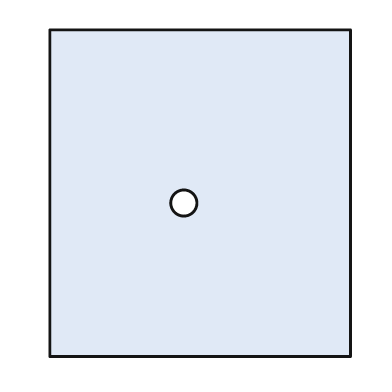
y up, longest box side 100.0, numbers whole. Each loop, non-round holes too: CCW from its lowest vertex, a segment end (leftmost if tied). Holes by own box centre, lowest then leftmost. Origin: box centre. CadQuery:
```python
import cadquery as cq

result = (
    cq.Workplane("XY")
    .moveTo(-46.0, -50.0)
    .lineTo(46.0, -50.0)
    .lineTo(46.0, 50.0)
    .lineTo(-46.0, 50.0)
    .close()
    .moveTo(-5.0, -3.0)
    .circle(4.0)
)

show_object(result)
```